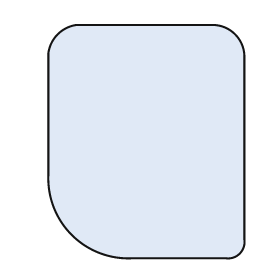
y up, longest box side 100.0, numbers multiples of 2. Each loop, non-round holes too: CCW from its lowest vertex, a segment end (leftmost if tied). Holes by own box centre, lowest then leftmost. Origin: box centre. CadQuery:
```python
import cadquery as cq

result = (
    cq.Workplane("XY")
    .moveTo(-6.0, -50.0)
    .lineTo(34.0, -50.0)
    .threePointArc((40.0, -48.0), (42.0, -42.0))
    .lineTo(42.0, 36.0)
    .threePointArc((38.0, 46.0), (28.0, 50.0))
    .lineTo(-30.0, 50.0)
    .threePointArc((-38.0, 46.0), (-42.0, 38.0))
    .lineTo(-42.0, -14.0)
    .threePointArc((-32.0, -40.0), (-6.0, -50.0))
    .close()
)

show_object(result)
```